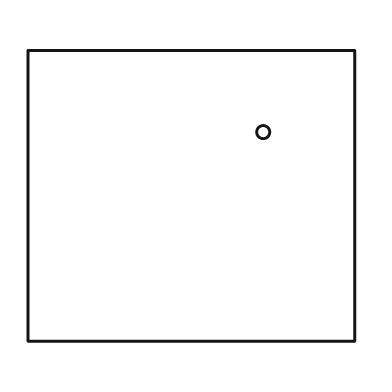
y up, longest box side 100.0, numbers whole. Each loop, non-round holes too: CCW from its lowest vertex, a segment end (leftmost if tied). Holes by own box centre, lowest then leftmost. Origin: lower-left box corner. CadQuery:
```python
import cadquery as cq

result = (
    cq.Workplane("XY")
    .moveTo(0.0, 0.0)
    .lineTo(100.0, 0.0)
    .lineTo(100.0, 89.0)
    .lineTo(0.0, 89.0)
    .close()
    .moveTo(72.0, 64.0)
    .circle(2.0)
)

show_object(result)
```